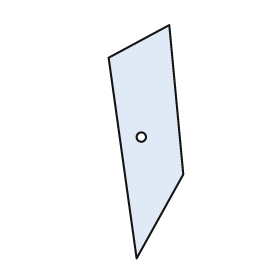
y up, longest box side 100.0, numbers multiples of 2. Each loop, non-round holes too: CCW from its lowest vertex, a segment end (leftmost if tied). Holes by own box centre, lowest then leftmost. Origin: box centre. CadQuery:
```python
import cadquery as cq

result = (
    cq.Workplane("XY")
    .moveTo(-4.0, -50.0)
    .lineTo(16.0, -14.0)
    .lineTo(10.0, 50.0)
    .lineTo(-16.0, 36.0)
    .close()
    .moveTo(-2.0, 2.0)
    .circle(2.0)
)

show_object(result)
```